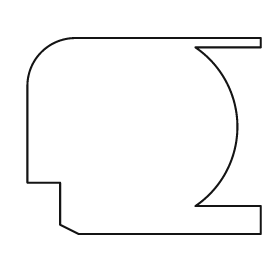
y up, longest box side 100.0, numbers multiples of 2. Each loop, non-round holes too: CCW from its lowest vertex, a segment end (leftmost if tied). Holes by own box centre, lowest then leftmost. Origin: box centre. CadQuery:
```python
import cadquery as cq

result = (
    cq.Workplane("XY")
    .moveTo(-28.0, -42.0)
    .lineTo(50.0, -42.0)
    .lineTo(50.0, -30.0)
    .lineTo(22.0, -30.0)
    .threePointArc((40.0, 4.0), (22.0, 38.0))
    .lineTo(50.0, 38.0)
    .lineTo(50.0, 42.0)
    .lineTo(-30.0, 42.0)
    .threePointArc((-44.0, 36.0), (-50.0, 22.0))
    .lineTo(-50.0, -20.0)
    .lineTo(-36.0, -20.0)
    .lineTo(-36.0, -38.0)
    .close()
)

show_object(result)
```